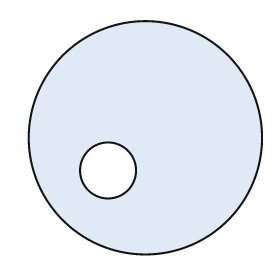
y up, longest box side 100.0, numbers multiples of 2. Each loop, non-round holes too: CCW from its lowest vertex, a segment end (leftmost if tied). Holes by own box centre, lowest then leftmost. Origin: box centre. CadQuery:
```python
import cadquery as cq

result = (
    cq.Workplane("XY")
    .moveTo(0.0, 0.0)
    .circle(50.0)
    .moveTo(-16.0, -14.0)
    .circle(12.0)
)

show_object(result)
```